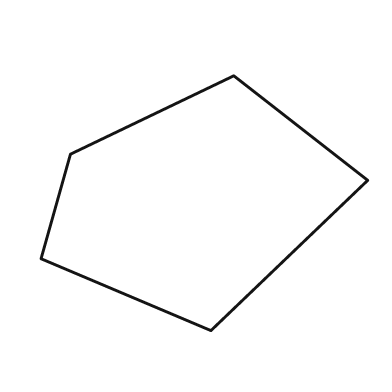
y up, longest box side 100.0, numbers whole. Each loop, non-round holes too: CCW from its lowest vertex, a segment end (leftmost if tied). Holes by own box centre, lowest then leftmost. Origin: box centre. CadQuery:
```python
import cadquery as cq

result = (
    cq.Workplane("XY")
    .moveTo(2.0, -39.0)
    .lineTo(50.0, 7.0)
    .lineTo(9.0, 39.0)
    .lineTo(-41.0, 15.0)
    .lineTo(-50.0, -17.0)
    .close()
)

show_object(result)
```